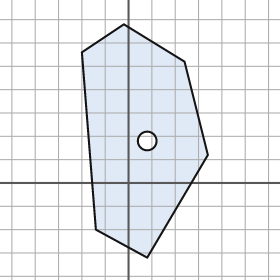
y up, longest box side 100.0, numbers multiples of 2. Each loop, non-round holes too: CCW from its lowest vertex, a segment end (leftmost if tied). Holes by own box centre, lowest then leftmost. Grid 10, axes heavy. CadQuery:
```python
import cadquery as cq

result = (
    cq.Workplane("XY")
    .moveTo(8.0, -32.0)
    .lineTo(34.0, 12.0)
    .lineTo(24.0, 52.0)
    .lineTo(-2.0, 68.0)
    .lineTo(-20.0, 56.0)
    .lineTo(-14.0, -20.0)
    .close()
    .moveTo(8.0, 18.0)
    .circle(4.0)
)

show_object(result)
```